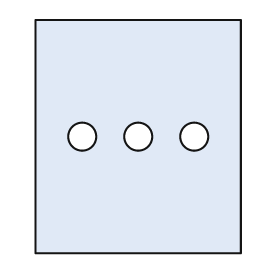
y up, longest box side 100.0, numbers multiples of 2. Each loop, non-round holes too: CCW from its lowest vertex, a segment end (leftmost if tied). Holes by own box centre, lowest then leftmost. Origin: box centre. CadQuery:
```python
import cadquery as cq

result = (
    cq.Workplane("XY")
    .moveTo(-44.0, -50.0)
    .lineTo(44.0, -50.0)
    .lineTo(44.0, 50.0)
    .lineTo(-44.0, 50.0)
    .close()
    .moveTo(-24.0, 0.0)
    .circle(6.0)
    .moveTo(0.0, 0.0)
    .circle(6.0)
    .moveTo(24.0, 0.0)
    .circle(6.0)
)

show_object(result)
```